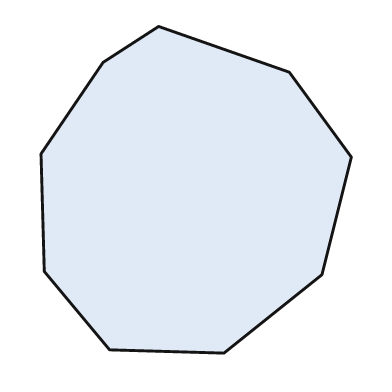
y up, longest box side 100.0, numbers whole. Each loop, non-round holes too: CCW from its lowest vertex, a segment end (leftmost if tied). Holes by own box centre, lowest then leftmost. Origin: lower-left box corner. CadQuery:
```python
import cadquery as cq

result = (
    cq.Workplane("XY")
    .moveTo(56.0, 0.0)
    .lineTo(86.0, 24.0)
    .lineTo(95.0, 60.0)
    .lineTo(76.0, 86.0)
    .lineTo(36.0, 100.0)
    .lineTo(19.0, 89.0)
    .lineTo(0.0, 61.0)
    .lineTo(1.0, 25.0)
    .lineTo(21.0, 1.0)
    .close()
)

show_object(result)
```